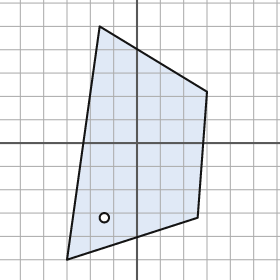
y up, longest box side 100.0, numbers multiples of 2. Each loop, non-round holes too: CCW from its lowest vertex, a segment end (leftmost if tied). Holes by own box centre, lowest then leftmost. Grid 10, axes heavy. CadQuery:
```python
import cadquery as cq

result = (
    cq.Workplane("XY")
    .moveTo(-30.0, -50.0)
    .lineTo(26.0, -32.0)
    .lineTo(30.0, 22.0)
    .lineTo(-16.0, 50.0)
    .close()
    .moveTo(-14.0, -32.0)
    .circle(2.0)
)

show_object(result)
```